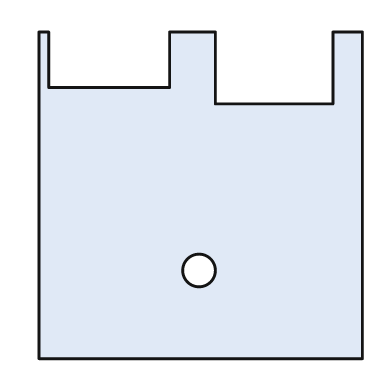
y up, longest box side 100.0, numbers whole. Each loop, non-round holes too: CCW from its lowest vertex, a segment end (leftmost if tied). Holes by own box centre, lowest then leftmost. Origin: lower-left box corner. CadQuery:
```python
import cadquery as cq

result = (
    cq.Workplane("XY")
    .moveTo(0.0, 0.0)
    .lineTo(99.0, 0.0)
    .lineTo(99.0, 100.0)
    .lineTo(90.0, 100.0)
    .lineTo(90.0, 78.0)
    .lineTo(54.0, 78.0)
    .lineTo(54.0, 100.0)
    .lineTo(40.0, 100.0)
    .lineTo(40.0, 83.0)
    .lineTo(3.0, 83.0)
    .lineTo(3.0, 100.0)
    .lineTo(0.0, 100.0)
    .close()
    .moveTo(49.0, 27.0)
    .circle(5.0)
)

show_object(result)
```